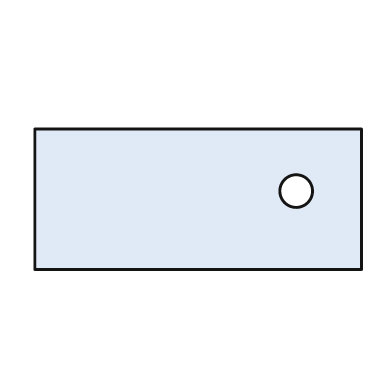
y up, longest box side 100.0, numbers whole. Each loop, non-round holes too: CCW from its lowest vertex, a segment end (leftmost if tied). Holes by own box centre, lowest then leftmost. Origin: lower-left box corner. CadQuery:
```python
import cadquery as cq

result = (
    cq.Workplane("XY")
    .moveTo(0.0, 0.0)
    .lineTo(100.0, 0.0)
    .lineTo(100.0, 43.0)
    .lineTo(0.0, 43.0)
    .close()
    .moveTo(80.0, 24.0)
    .circle(5.0)
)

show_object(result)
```